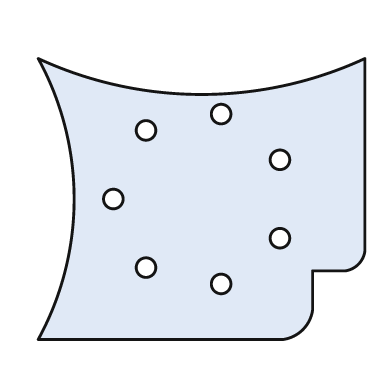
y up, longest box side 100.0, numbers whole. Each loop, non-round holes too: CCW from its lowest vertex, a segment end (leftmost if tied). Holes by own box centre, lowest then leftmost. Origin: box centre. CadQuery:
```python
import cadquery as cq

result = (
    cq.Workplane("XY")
    .moveTo(-50.0, -43.0)
    .lineTo(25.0, -43.0)
    .threePointArc((31.0, -40.0), (34.0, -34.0))
    .lineTo(34.0, -22.0)
    .lineTo(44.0, -22.0)
    .threePointArc((48.0, -20.0), (50.0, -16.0))
    .lineTo(50.0, 43.0)
    .threePointArc((0.0, 32.0), (-50.0, 43.0))
    .threePointArc((-39.0, 0.0), (-50.0, -43.0))
    .close()
    .moveTo(6.0, -26.0)
    .circle(3.0)
    .moveTo(-17.0, -21.0)
    .circle(3.0)
    .moveTo(24.0, -12.0)
    .circle(3.0)
    .moveTo(-27.0, 0.0)
    .circle(3.0)
    .moveTo(24.0, 12.0)
    .circle(3.0)
    .moveTo(-17.0, 21.0)
    .circle(3.0)
    .moveTo(6.0, 26.0)
    .circle(3.0)
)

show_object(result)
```